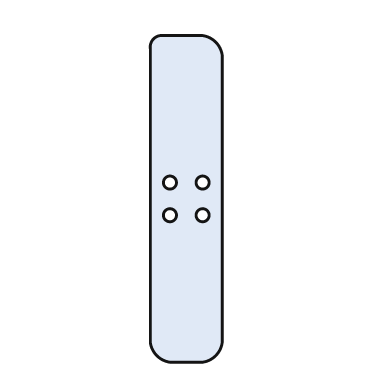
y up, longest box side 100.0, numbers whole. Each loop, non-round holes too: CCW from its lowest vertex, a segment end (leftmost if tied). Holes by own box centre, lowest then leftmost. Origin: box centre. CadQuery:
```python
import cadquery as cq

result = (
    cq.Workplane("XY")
    .moveTo(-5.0, -50.0)
    .lineTo(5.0, -50.0)
    .threePointArc((9.0, -48.0), (11.0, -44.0))
    .lineTo(11.0, 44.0)
    .threePointArc((9.0, 48.0), (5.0, 50.0))
    .lineTo(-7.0, 50.0)
    .threePointArc((-10.0, 49.0), (-11.0, 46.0))
    .lineTo(-11.0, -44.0)
    .threePointArc((-9.0, -48.0), (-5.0, -50.0))
    .close()
    .moveTo(-5.0, -5.0)
    .circle(2.0)
    .moveTo(5.0, -5.0)
    .circle(2.0)
    .moveTo(-5.0, 5.0)
    .circle(2.0)
    .moveTo(5.0, 5.0)
    .circle(2.0)
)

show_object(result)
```